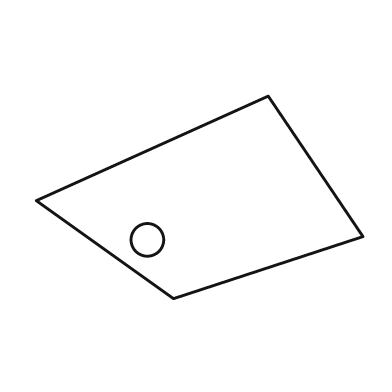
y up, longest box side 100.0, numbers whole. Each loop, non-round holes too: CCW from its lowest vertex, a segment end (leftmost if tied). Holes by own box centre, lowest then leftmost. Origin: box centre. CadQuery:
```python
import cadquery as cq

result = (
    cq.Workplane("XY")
    .moveTo(-8.0, -31.0)
    .lineTo(50.0, -12.0)
    .lineTo(21.0, 31.0)
    .lineTo(-50.0, -1.0)
    .close()
    .moveTo(-16.0, -13.0)
    .circle(5.0)
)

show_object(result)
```